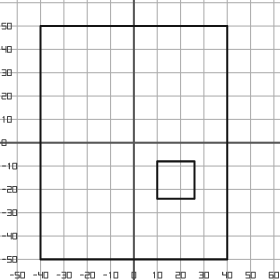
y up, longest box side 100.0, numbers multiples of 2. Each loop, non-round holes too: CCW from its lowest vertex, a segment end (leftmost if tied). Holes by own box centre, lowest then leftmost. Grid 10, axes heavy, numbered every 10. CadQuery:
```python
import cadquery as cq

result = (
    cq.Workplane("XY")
    .moveTo(-40.0, -50.0)
    .lineTo(40.0, -50.0)
    .lineTo(40.0, 50.0)
    .lineTo(-40.0, 50.0)
    .close()
    .moveTo(10.0, -24.0)
    .lineTo(26.0, -24.0)
    .lineTo(26.0, -8.0)
    .lineTo(10.0, -8.0)
    .close()
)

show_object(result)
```